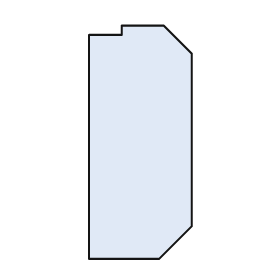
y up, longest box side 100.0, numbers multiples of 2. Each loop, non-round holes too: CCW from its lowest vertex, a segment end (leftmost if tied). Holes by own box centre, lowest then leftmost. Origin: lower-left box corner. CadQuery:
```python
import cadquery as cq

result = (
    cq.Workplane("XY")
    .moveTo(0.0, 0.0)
    .lineTo(30.0, 0.0)
    .lineTo(44.0, 14.0)
    .lineTo(44.0, 88.0)
    .lineTo(32.0, 100.0)
    .lineTo(14.0, 100.0)
    .lineTo(14.0, 96.0)
    .lineTo(0.0, 96.0)
    .close()
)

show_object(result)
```